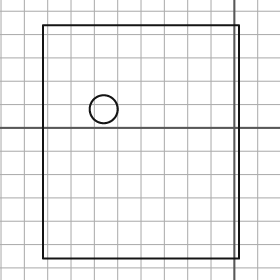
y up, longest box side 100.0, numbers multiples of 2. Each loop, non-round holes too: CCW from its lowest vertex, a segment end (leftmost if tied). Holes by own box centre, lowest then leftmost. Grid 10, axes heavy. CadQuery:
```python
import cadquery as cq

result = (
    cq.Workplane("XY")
    .moveTo(-82.0, -56.0)
    .lineTo(2.0, -56.0)
    .lineTo(2.0, 44.0)
    .lineTo(-82.0, 44.0)
    .close()
    .moveTo(-56.0, 8.0)
    .circle(6.0)
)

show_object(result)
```